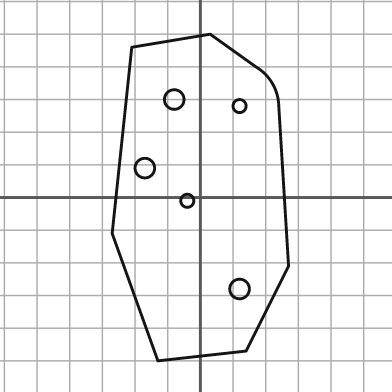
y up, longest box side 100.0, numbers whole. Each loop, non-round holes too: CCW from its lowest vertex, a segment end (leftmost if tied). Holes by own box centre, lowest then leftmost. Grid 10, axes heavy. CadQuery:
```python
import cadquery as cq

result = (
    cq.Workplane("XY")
    .moveTo(-13.0, -50.0)
    .lineTo(14.0, -47.0)
    .lineTo(27.0, -21.0)
    .lineTo(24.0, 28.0)
    .threePointArc((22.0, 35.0), (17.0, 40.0))
    .lineTo(3.0, 50.0)
    .lineTo(-21.0, 46.0)
    .lineTo(-27.0, -11.0)
    .close()
    .moveTo(12.0, -28.0)
    .circle(3.0)
    .moveTo(-4.0, -1.0)
    .circle(2.0)
    .moveTo(-17.0, 9.0)
    .circle(3.0)
    .moveTo(12.0, 28.0)
    .circle(2.0)
    .moveTo(-8.0, 30.0)
    .circle(3.0)
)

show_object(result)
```